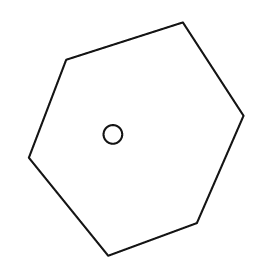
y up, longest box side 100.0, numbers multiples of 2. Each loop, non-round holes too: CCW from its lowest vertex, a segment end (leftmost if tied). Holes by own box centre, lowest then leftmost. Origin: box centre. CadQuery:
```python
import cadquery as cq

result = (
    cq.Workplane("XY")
    .moveTo(-12.0, -50.0)
    .lineTo(26.0, -36.0)
    .lineTo(46.0, 10.0)
    .lineTo(20.0, 50.0)
    .lineTo(-30.0, 34.0)
    .lineTo(-46.0, -8.0)
    .close()
    .moveTo(-10.0, 2.0)
    .circle(4.0)
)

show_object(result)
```